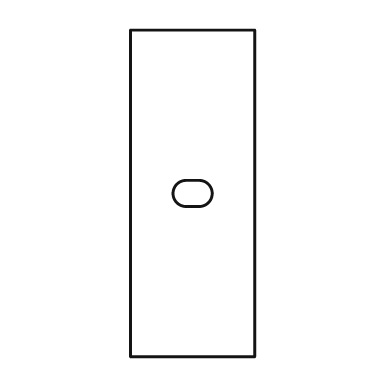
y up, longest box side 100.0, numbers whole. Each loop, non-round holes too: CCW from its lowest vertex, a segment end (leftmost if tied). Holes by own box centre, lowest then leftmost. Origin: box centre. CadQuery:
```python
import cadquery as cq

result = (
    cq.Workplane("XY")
    .moveTo(-19.0, -50.0)
    .lineTo(19.0, -50.0)
    .lineTo(19.0, 50.0)
    .lineTo(-19.0, 50.0)
    .close()
    .moveTo(-2.0, -4.0)
    .lineTo(2.0, -4.0)
    .threePointArc((6.0, 0.0), (2.0, 4.0))
    .lineTo(-2.0, 4.0)
    .threePointArc((-6.0, 0.0), (-2.0, -4.0))
    .close()
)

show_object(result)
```